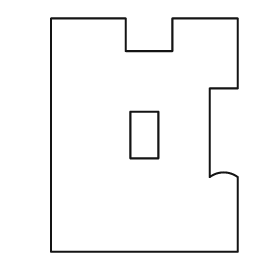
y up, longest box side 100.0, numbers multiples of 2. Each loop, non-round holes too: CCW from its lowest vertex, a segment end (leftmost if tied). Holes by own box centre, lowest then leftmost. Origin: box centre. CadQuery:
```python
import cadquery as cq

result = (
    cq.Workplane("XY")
    .moveTo(-40.0, -50.0)
    .lineTo(40.0, -50.0)
    .lineTo(40.0, -18.0)
    .threePointArc((34.0, -16.0), (28.0, -18.0))
    .lineTo(28.0, 20.0)
    .lineTo(40.0, 20.0)
    .lineTo(40.0, 50.0)
    .lineTo(12.0, 50.0)
    .lineTo(12.0, 36.0)
    .lineTo(-8.0, 36.0)
    .lineTo(-8.0, 50.0)
    .lineTo(-40.0, 50.0)
    .close()
    .moveTo(-6.0, -10.0)
    .lineTo(6.0, -10.0)
    .lineTo(6.0, 10.0)
    .lineTo(-6.0, 10.0)
    .close()
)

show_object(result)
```